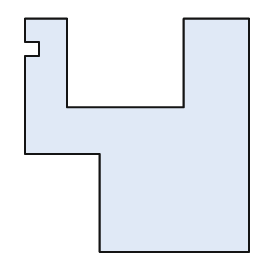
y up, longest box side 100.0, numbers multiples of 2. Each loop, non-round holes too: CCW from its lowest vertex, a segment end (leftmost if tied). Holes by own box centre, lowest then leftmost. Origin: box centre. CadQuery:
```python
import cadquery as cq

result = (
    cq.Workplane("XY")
    .moveTo(-16.0, -50.0)
    .lineTo(48.0, -50.0)
    .lineTo(48.0, 50.0)
    .lineTo(20.0, 50.0)
    .lineTo(20.0, 12.0)
    .lineTo(-30.0, 12.0)
    .lineTo(-30.0, 50.0)
    .lineTo(-48.0, 50.0)
    .lineTo(-48.0, 40.0)
    .lineTo(-42.0, 40.0)
    .lineTo(-42.0, 34.0)
    .lineTo(-48.0, 34.0)
    .lineTo(-48.0, -8.0)
    .lineTo(-16.0, -8.0)
    .close()
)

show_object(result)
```